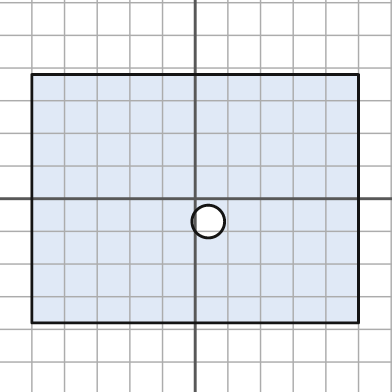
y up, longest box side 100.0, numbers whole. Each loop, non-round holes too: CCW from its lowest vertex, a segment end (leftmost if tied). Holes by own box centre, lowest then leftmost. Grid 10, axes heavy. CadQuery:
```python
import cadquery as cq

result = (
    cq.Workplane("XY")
    .moveTo(-50.0, -38.0)
    .lineTo(50.0, -38.0)
    .lineTo(50.0, 38.0)
    .lineTo(-50.0, 38.0)
    .close()
    .moveTo(4.0, -7.0)
    .circle(5.0)
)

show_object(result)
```